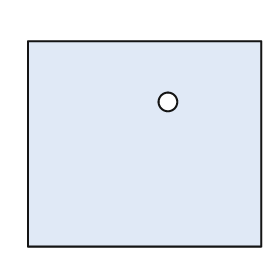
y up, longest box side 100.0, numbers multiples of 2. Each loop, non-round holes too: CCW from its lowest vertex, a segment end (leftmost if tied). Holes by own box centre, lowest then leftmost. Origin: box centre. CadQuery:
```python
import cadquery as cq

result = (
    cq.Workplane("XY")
    .moveTo(-50.0, -44.0)
    .lineTo(50.0, -44.0)
    .lineTo(50.0, 44.0)
    .lineTo(-50.0, 44.0)
    .close()
    .moveTo(10.0, 18.0)
    .circle(4.0)
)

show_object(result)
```